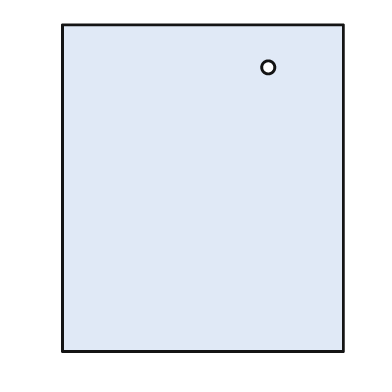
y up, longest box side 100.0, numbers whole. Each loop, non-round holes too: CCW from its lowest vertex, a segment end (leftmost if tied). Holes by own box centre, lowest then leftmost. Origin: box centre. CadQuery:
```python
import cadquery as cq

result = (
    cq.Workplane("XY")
    .moveTo(-43.0, -50.0)
    .lineTo(43.0, -50.0)
    .lineTo(43.0, 50.0)
    .lineTo(-43.0, 50.0)
    .close()
    .moveTo(20.0, 37.0)
    .circle(2.0)
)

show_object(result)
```